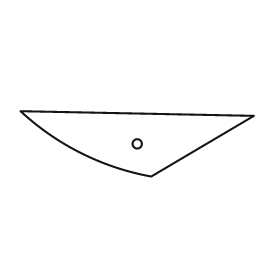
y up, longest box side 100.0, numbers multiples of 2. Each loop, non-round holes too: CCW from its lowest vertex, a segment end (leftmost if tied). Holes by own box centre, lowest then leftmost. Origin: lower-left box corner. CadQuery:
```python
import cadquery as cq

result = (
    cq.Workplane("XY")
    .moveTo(56.0, 0.0)
    .lineTo(100.0, 26.0)
    .lineTo(0.0, 28.0)
    .threePointArc((26.0, 10.0), (56.0, 0.0))
    .close()
    .moveTo(50.0, 14.0)
    .circle(2.0)
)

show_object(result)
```